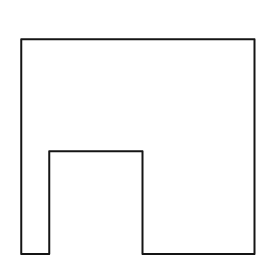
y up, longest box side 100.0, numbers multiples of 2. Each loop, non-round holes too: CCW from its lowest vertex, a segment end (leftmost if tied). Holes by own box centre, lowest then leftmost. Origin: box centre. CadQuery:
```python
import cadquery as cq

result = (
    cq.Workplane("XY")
    .moveTo(-50.0, -46.0)
    .lineTo(-38.0, -46.0)
    .lineTo(-38.0, -2.0)
    .lineTo(2.0, -2.0)
    .lineTo(2.0, -46.0)
    .lineTo(50.0, -46.0)
    .lineTo(50.0, 46.0)
    .lineTo(-50.0, 46.0)
    .close()
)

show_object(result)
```